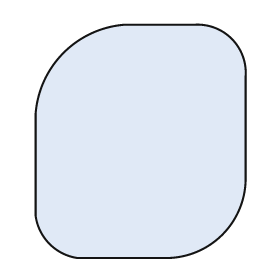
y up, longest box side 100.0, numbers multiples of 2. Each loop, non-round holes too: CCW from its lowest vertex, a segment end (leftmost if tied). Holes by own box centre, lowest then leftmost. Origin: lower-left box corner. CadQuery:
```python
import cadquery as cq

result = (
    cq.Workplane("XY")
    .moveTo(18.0, 0.0)
    .lineTo(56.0, 0.0)
    .threePointArc((80.0, 10.0), (90.0, 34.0))
    .lineTo(90.0, 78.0)
    .threePointArc((84.0, 94.0), (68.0, 100.0))
    .lineTo(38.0, 100.0)
    .threePointArc((12.0, 88.0), (0.0, 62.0))
    .lineTo(0.0, 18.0)
    .threePointArc((6.0, 6.0), (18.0, 0.0))
    .close()
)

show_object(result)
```